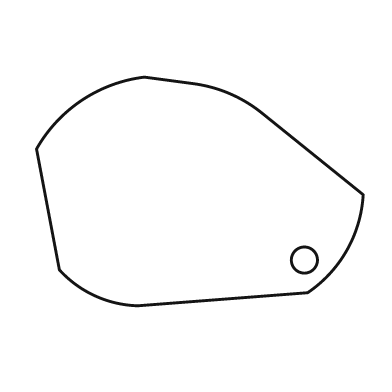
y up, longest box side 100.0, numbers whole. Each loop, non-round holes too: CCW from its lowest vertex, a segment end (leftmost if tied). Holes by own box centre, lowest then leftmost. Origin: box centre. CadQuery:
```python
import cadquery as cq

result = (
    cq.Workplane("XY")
    .moveTo(-19.0, -35.0)
    .lineTo(33.0, -31.0)
    .threePointArc((45.0, -18.0), (50.0, -1.0))
    .lineTo(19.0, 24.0)
    .threePointArc((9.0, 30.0), (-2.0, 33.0))
    .lineTo(-17.0, 35.0)
    .threePointArc((-36.0, 28.0), (-50.0, 13.0))
    .lineTo(-43.0, -24.0)
    .threePointArc((-32.0, -32.0), (-19.0, -35.0))
    .close()
    .moveTo(32.0, -21.0)
    .circle(4.0)
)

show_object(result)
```